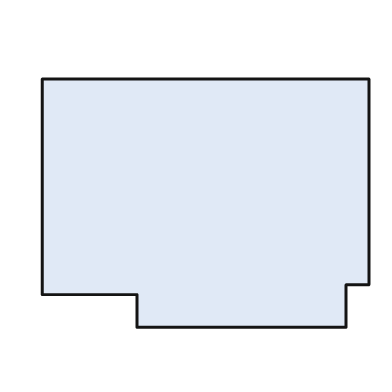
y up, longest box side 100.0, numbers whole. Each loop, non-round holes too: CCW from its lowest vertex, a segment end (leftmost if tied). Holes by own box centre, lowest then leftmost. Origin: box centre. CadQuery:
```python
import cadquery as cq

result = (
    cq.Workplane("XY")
    .moveTo(-21.0, -38.0)
    .lineTo(43.0, -38.0)
    .lineTo(43.0, -25.0)
    .lineTo(50.0, -25.0)
    .lineTo(50.0, 38.0)
    .lineTo(-50.0, 38.0)
    .lineTo(-50.0, -28.0)
    .lineTo(-21.0, -28.0)
    .close()
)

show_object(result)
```